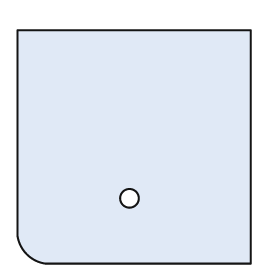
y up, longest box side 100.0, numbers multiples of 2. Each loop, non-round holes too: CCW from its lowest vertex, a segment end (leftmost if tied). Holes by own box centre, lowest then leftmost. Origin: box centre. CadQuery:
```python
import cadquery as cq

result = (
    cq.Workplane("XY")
    .moveTo(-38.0, -50.0)
    .lineTo(50.0, -50.0)
    .lineTo(50.0, 50.0)
    .lineTo(-50.0, 50.0)
    .lineTo(-50.0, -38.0)
    .threePointArc((-46.0, -46.0), (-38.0, -50.0))
    .close()
    .moveTo(-2.0, -22.0)
    .circle(4.0)
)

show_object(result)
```